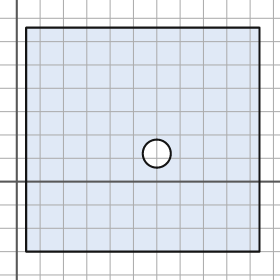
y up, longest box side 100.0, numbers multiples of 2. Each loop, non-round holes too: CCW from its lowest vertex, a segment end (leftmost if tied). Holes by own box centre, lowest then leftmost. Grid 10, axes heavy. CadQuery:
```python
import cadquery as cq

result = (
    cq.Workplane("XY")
    .moveTo(4.0, -30.0)
    .lineTo(104.0, -30.0)
    .lineTo(104.0, 66.0)
    .lineTo(4.0, 66.0)
    .close()
    .moveTo(60.0, 12.0)
    .circle(6.0)
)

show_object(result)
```